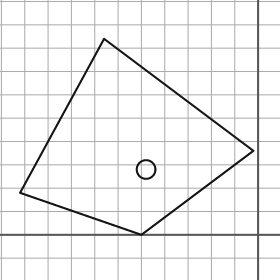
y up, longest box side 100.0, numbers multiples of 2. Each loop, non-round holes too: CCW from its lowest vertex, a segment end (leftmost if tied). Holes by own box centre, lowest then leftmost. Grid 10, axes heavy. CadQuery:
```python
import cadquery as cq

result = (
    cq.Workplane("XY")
    .moveTo(-50.0, 0.0)
    .lineTo(-2.0, 36.0)
    .lineTo(-66.0, 84.0)
    .lineTo(-102.0, 18.0)
    .close()
    .moveTo(-48.0, 28.0)
    .circle(4.0)
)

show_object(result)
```